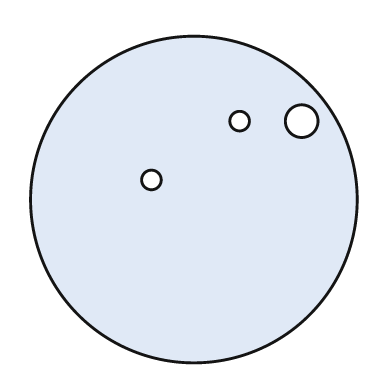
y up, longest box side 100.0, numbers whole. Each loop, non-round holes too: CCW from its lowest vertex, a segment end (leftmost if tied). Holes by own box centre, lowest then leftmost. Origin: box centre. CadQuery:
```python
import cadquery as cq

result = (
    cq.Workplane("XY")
    .moveTo(0.0, 0.0)
    .circle(50.0)
    .moveTo(-13.0, 6.0)
    .circle(3.0)
    .moveTo(14.0, 24.0)
    .circle(3.0)
    .moveTo(33.0, 24.0)
    .circle(5.0)
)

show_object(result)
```